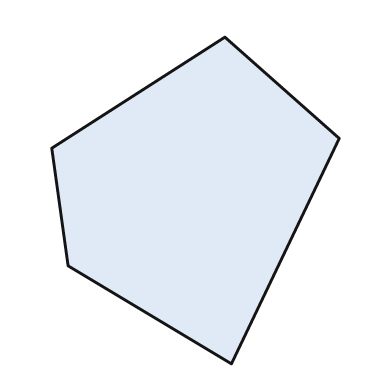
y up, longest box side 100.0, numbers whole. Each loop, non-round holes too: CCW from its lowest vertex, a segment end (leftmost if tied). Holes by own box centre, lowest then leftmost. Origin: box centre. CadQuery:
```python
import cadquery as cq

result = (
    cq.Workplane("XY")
    .moveTo(11.0, -50.0)
    .lineTo(44.0, 19.0)
    .lineTo(9.0, 50.0)
    .lineTo(-44.0, 16.0)
    .lineTo(-39.0, -20.0)
    .close()
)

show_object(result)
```